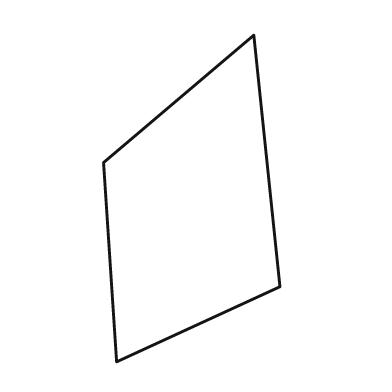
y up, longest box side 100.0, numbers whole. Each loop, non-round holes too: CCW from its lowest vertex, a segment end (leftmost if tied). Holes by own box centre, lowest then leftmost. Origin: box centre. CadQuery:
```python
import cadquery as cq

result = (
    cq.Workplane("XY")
    .moveTo(-23.0, -50.0)
    .lineTo(27.0, -27.0)
    .lineTo(19.0, 50.0)
    .lineTo(-27.0, 11.0)
    .close()
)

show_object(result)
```